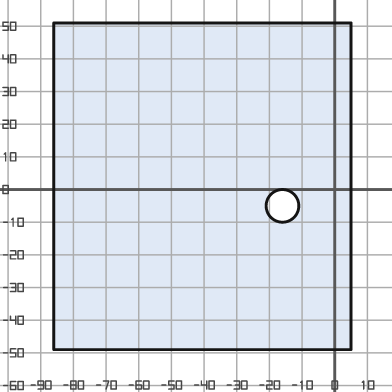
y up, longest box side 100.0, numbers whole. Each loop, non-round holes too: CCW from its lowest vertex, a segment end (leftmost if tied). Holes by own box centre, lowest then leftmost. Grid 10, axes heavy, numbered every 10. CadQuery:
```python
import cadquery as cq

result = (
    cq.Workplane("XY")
    .moveTo(-86.0, -49.0)
    .lineTo(5.0, -49.0)
    .lineTo(5.0, 51.0)
    .lineTo(-86.0, 51.0)
    .close()
    .moveTo(-16.0, -5.0)
    .circle(5.0)
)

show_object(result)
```